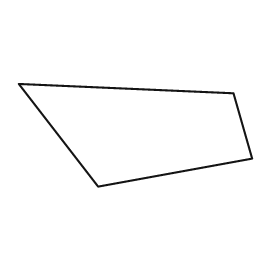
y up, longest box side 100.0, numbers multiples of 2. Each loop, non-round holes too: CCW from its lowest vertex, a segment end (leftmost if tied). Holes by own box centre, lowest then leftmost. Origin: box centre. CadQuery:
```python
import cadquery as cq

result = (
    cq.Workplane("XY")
    .moveTo(-16.0, -22.0)
    .lineTo(50.0, -10.0)
    .lineTo(42.0, 18.0)
    .lineTo(-50.0, 22.0)
    .close()
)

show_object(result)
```